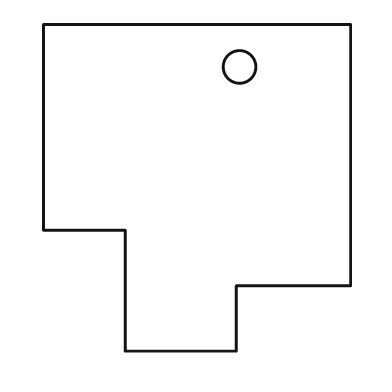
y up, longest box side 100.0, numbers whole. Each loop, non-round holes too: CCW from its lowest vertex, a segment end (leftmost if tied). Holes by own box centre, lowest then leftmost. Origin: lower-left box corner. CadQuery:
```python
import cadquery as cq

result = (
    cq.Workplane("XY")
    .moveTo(25.0, 0.0)
    .lineTo(59.0, 0.0)
    .lineTo(59.0, 20.0)
    .lineTo(94.0, 20.0)
    .lineTo(94.0, 100.0)
    .lineTo(0.0, 100.0)
    .lineTo(0.0, 37.0)
    .lineTo(25.0, 37.0)
    .close()
    .moveTo(60.0, 87.0)
    .circle(5.0)
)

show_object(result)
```